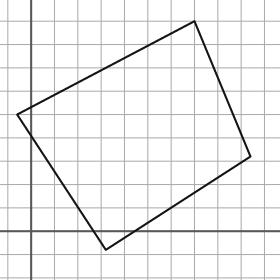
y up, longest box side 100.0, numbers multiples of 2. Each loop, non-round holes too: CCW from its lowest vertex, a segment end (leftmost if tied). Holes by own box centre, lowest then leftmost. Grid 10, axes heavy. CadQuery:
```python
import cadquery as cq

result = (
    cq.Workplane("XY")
    .moveTo(32.0, -8.0)
    .lineTo(94.0, 32.0)
    .lineTo(70.0, 90.0)
    .lineTo(-6.0, 50.0)
    .close()
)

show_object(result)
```